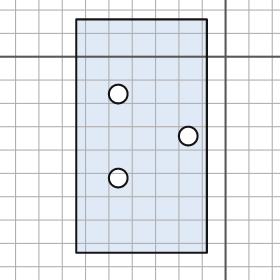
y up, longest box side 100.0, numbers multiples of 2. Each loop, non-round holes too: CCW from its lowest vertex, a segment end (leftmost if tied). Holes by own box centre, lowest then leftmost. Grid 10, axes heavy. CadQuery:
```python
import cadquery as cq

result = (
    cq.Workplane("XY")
    .moveTo(-64.0, -84.0)
    .lineTo(-8.0, -84.0)
    .lineTo(-8.0, 16.0)
    .lineTo(-64.0, 16.0)
    .close()
    .moveTo(-46.0, -52.0)
    .circle(4.0)
    .moveTo(-16.0, -34.0)
    .circle(4.0)
    .moveTo(-46.0, -16.0)
    .circle(4.0)
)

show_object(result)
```